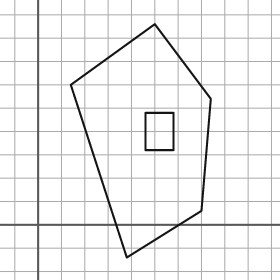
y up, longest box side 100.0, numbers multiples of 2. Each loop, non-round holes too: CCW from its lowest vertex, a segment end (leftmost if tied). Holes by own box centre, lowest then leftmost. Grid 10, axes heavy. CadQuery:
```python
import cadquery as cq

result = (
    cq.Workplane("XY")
    .moveTo(38.0, -14.0)
    .lineTo(70.0, 6.0)
    .lineTo(74.0, 54.0)
    .lineTo(50.0, 86.0)
    .lineTo(14.0, 60.0)
    .close()
    .moveTo(46.0, 32.0)
    .lineTo(58.0, 32.0)
    .lineTo(58.0, 48.0)
    .lineTo(46.0, 48.0)
    .close()
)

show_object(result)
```